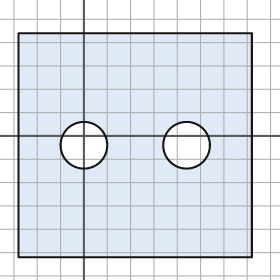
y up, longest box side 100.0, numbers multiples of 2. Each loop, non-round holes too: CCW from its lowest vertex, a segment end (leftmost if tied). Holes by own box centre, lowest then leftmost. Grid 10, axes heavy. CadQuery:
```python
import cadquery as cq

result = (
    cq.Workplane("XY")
    .moveTo(-28.0, -52.0)
    .lineTo(72.0, -52.0)
    .lineTo(72.0, 44.0)
    .lineTo(-28.0, 44.0)
    .close()
    .moveTo(0.0, -4.0)
    .circle(10.0)
    .moveTo(44.0, -4.0)
    .circle(10.0)
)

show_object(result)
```